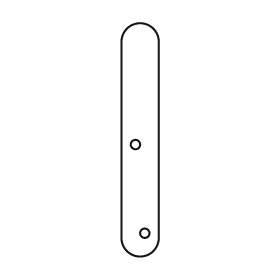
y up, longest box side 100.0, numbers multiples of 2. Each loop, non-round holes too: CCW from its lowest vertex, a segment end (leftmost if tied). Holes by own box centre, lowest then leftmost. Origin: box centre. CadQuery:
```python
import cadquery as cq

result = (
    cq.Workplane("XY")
    .moveTo(-8.0, -42.0)
    .threePointArc((0.0, -50.0), (8.0, -42.0))
    .lineTo(8.0, 42.0)
    .threePointArc((0.0, 50.0), (-8.0, 42.0))
    .close()
    .moveTo(2.0, -40.0)
    .circle(2.0)
    .moveTo(-2.0, -2.0)
    .circle(2.0)
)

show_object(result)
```